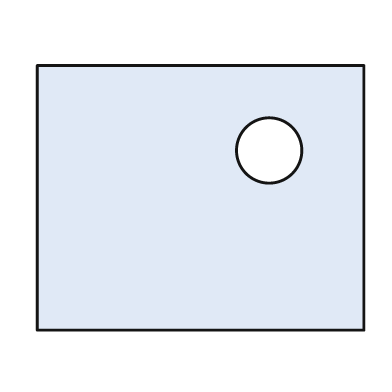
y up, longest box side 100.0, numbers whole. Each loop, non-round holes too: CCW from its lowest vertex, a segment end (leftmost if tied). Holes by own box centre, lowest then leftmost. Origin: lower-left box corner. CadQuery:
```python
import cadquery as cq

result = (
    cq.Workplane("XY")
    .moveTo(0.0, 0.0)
    .lineTo(100.0, 0.0)
    .lineTo(100.0, 81.0)
    .lineTo(0.0, 81.0)
    .close()
    .moveTo(71.0, 55.0)
    .circle(10.0)
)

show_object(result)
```